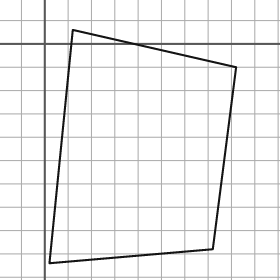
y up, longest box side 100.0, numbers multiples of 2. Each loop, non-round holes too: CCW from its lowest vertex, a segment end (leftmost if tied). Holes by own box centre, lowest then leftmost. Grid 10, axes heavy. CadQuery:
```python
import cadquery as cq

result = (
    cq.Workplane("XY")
    .moveTo(2.0, -94.0)
    .lineTo(72.0, -88.0)
    .lineTo(82.0, -10.0)
    .lineTo(12.0, 6.0)
    .close()
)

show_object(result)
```